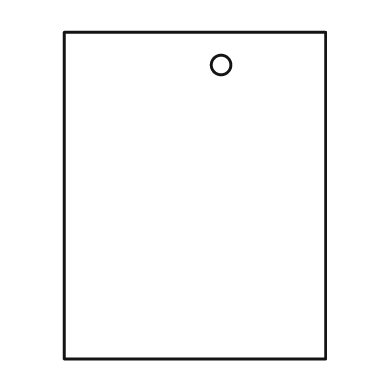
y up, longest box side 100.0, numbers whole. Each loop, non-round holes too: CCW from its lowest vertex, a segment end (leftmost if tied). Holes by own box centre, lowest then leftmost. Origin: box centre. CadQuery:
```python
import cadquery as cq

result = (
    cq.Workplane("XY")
    .moveTo(-40.0, -50.0)
    .lineTo(40.0, -50.0)
    .lineTo(40.0, 50.0)
    .lineTo(-40.0, 50.0)
    .close()
    .moveTo(8.0, 40.0)
    .circle(3.0)
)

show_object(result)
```